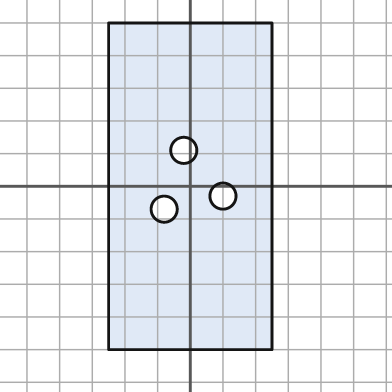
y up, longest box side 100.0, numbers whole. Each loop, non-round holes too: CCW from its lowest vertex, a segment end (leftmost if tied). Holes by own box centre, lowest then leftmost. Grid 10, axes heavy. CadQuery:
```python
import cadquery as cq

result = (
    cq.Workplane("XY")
    .moveTo(-25.0, -50.0)
    .lineTo(25.0, -50.0)
    .lineTo(25.0, 50.0)
    .lineTo(-25.0, 50.0)
    .close()
    .moveTo(-8.0, -7.0)
    .circle(4.0)
    .moveTo(10.0, -3.0)
    .circle(4.0)
    .moveTo(-2.0, 11.0)
    .circle(4.0)
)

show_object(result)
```